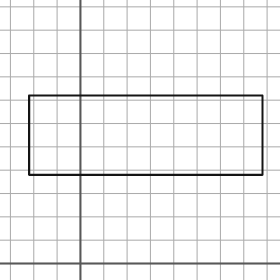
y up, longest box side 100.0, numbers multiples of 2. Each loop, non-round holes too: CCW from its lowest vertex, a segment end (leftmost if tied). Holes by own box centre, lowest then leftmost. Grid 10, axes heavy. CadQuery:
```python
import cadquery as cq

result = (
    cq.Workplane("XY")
    .moveTo(-22.0, 38.0)
    .lineTo(78.0, 38.0)
    .lineTo(78.0, 72.0)
    .lineTo(-22.0, 72.0)
    .close()
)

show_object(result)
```